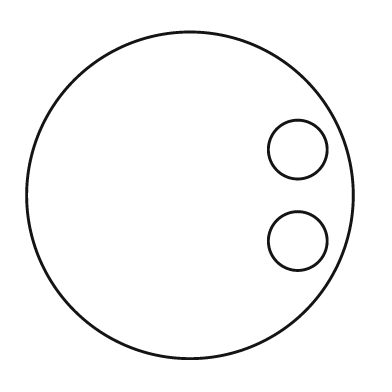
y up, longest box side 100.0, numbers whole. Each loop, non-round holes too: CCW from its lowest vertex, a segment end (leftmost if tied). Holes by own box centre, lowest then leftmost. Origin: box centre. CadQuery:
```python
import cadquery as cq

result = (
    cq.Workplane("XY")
    .moveTo(0.0, 0.0)
    .circle(50.0)
    .moveTo(33.0, -14.0)
    .circle(9.0)
    .moveTo(33.0, 14.0)
    .circle(9.0)
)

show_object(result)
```